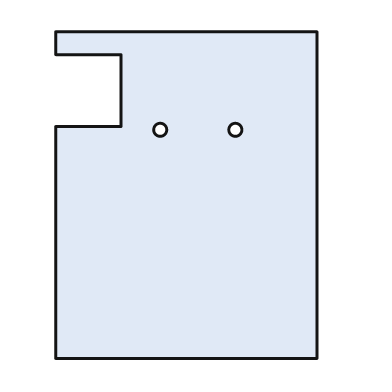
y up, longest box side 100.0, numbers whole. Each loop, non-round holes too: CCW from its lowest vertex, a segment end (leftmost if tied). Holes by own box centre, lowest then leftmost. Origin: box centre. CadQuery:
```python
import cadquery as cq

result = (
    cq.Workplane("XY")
    .moveTo(-40.0, -50.0)
    .lineTo(40.0, -50.0)
    .lineTo(40.0, 50.0)
    .lineTo(-40.0, 50.0)
    .lineTo(-40.0, 43.0)
    .lineTo(-20.0, 43.0)
    .lineTo(-20.0, 21.0)
    .lineTo(-40.0, 21.0)
    .close()
    .moveTo(-8.0, 20.0)
    .circle(2.0)
    .moveTo(15.0, 20.0)
    .circle(2.0)
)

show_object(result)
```